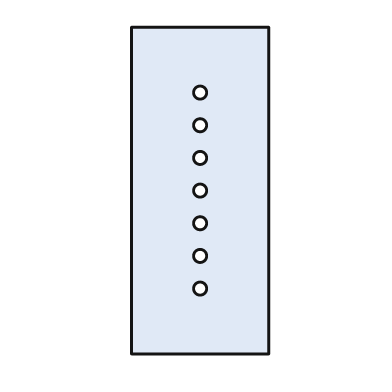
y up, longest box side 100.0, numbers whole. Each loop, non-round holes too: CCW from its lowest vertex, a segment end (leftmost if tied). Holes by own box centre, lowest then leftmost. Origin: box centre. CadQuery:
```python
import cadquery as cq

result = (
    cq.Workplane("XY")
    .moveTo(-21.0, -50.0)
    .lineTo(21.0, -50.0)
    .lineTo(21.0, 50.0)
    .lineTo(-21.0, 50.0)
    .close()
    .moveTo(0.0, -30.0)
    .circle(2.0)
    .moveTo(0.0, -20.0)
    .circle(2.0)
    .moveTo(0.0, -10.0)
    .circle(2.0)
    .moveTo(0.0, 0.0)
    .circle(2.0)
    .moveTo(0.0, 10.0)
    .circle(2.0)
    .moveTo(0.0, 20.0)
    .circle(2.0)
    .moveTo(0.0, 30.0)
    .circle(2.0)
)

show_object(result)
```